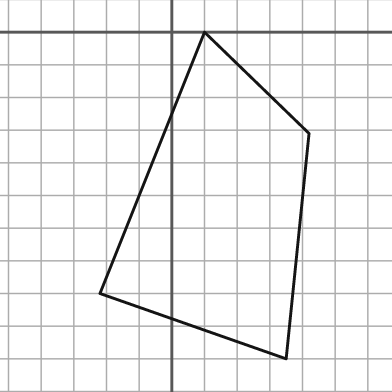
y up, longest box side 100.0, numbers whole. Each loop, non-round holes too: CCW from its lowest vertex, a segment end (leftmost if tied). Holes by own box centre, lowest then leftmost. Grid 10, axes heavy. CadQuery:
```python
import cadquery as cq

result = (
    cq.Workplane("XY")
    .moveTo(35.0, -100.0)
    .lineTo(42.0, -31.0)
    .lineTo(10.0, 0.0)
    .lineTo(-22.0, -80.0)
    .close()
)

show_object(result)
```